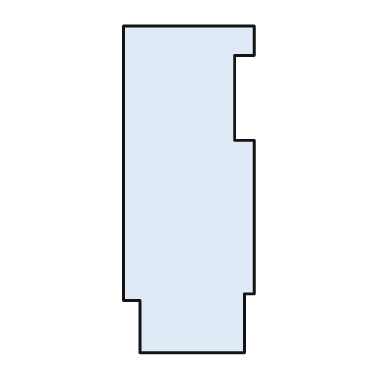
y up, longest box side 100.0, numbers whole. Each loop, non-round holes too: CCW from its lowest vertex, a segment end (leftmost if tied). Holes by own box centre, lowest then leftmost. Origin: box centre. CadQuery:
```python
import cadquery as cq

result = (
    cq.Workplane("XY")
    .moveTo(-15.0, -50.0)
    .lineTo(17.0, -50.0)
    .lineTo(17.0, -32.0)
    .lineTo(20.0, -32.0)
    .lineTo(20.0, 15.0)
    .lineTo(14.0, 15.0)
    .lineTo(14.0, 41.0)
    .lineTo(20.0, 41.0)
    .lineTo(20.0, 50.0)
    .lineTo(-20.0, 50.0)
    .lineTo(-20.0, -34.0)
    .lineTo(-15.0, -34.0)
    .close()
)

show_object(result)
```